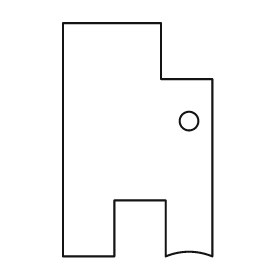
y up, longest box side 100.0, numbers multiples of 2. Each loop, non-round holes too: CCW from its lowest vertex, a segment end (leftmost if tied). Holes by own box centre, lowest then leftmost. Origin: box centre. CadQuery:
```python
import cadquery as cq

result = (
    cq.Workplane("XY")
    .moveTo(-32.0, -50.0)
    .lineTo(-10.0, -50.0)
    .lineTo(-10.0, -26.0)
    .lineTo(12.0, -26.0)
    .lineTo(12.0, -50.0)
    .threePointArc((22.0, -48.0), (32.0, -50.0))
    .lineTo(32.0, 26.0)
    .lineTo(10.0, 26.0)
    .lineTo(10.0, 50.0)
    .lineTo(-32.0, 50.0)
    .close()
    .moveTo(22.0, 8.0)
    .circle(4.0)
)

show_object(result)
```